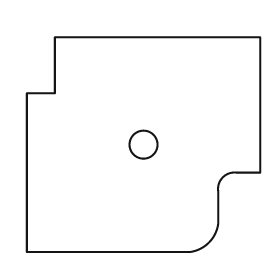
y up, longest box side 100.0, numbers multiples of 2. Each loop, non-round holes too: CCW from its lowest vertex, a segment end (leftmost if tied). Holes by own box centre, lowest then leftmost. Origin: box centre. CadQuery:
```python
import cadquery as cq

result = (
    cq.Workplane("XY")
    .moveTo(-50.0, -46.0)
    .lineTo(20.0, -46.0)
    .threePointArc((28.0, -42.0), (32.0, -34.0))
    .lineTo(32.0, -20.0)
    .threePointArc((34.0, -14.0), (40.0, -12.0))
    .lineTo(50.0, -12.0)
    .lineTo(50.0, 46.0)
    .lineTo(-38.0, 46.0)
    .lineTo(-38.0, 22.0)
    .lineTo(-50.0, 22.0)
    .close()
    .moveTo(0.0, 0.0)
    .circle(6.0)
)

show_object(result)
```